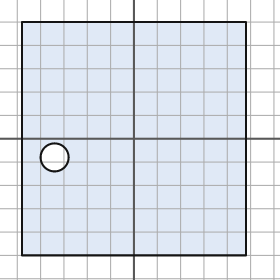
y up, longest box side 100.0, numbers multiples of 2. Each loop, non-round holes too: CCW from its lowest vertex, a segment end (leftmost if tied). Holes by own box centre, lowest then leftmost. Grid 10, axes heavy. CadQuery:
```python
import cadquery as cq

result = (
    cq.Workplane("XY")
    .moveTo(-48.0, -50.0)
    .lineTo(48.0, -50.0)
    .lineTo(48.0, 50.0)
    .lineTo(-48.0, 50.0)
    .close()
    .moveTo(-34.0, -8.0)
    .circle(6.0)
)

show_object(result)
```